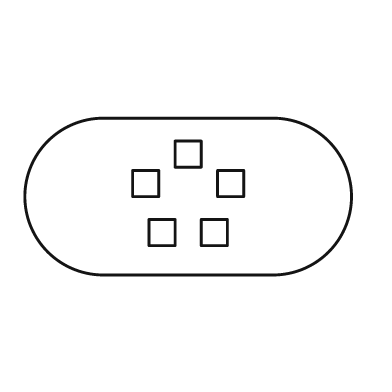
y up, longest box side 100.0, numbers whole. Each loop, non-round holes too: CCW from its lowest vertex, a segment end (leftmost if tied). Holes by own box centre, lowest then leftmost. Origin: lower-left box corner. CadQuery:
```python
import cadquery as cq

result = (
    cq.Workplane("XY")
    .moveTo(24.0, 0.0)
    .lineTo(76.0, 0.0)
    .threePointArc((100.0, 24.0), (76.0, 48.0))
    .lineTo(24.0, 48.0)
    .threePointArc((0.0, 24.0), (24.0, 0.0))
    .close()
    .moveTo(38.0, 9.0)
    .lineTo(46.0, 9.0)
    .lineTo(46.0, 17.0)
    .lineTo(38.0, 17.0)
    .close()
    .moveTo(54.0, 9.0)
    .lineTo(62.0, 9.0)
    .lineTo(62.0, 17.0)
    .lineTo(54.0, 17.0)
    .close()
    .moveTo(33.0, 24.0)
    .lineTo(41.0, 24.0)
    .lineTo(41.0, 32.0)
    .lineTo(33.0, 32.0)
    .close()
    .moveTo(59.0, 24.0)
    .lineTo(67.0, 24.0)
    .lineTo(67.0, 32.0)
    .lineTo(59.0, 32.0)
    .close()
    .moveTo(46.0, 33.0)
    .lineTo(54.0, 33.0)
    .lineTo(54.0, 41.0)
    .lineTo(46.0, 41.0)
    .close()
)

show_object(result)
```